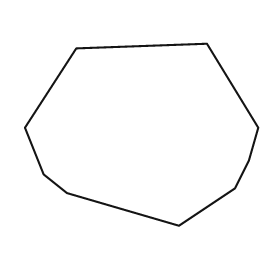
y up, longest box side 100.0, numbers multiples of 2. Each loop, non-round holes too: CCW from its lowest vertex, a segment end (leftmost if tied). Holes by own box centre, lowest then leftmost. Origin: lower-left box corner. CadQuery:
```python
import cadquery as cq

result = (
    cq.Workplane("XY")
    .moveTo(66.0, 0.0)
    .lineTo(90.0, 16.0)
    .lineTo(96.0, 28.0)
    .lineTo(100.0, 42.0)
    .lineTo(78.0, 78.0)
    .lineTo(22.0, 76.0)
    .lineTo(0.0, 42.0)
    .lineTo(8.0, 22.0)
    .lineTo(18.0, 14.0)
    .close()
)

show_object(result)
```